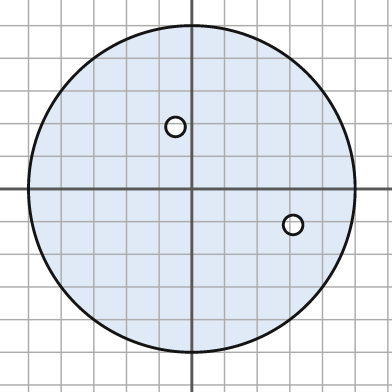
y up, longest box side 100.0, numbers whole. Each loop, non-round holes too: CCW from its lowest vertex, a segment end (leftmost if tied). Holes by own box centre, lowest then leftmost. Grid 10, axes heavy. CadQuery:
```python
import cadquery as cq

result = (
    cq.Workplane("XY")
    .moveTo(0.0, 0.0)
    .circle(50.0)
    .moveTo(31.0, -11.0)
    .circle(3.0)
    .moveTo(-5.0, 19.0)
    .circle(3.0)
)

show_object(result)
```